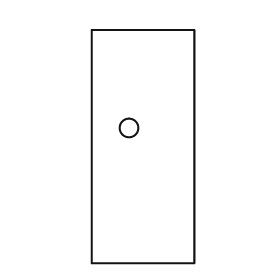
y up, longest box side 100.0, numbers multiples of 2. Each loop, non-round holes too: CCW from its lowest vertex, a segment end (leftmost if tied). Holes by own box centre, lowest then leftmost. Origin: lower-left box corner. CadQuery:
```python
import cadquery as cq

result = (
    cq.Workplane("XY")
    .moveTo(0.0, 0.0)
    .lineTo(44.0, 0.0)
    .lineTo(44.0, 100.0)
    .lineTo(0.0, 100.0)
    .close()
    .moveTo(16.0, 58.0)
    .circle(4.0)
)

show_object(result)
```